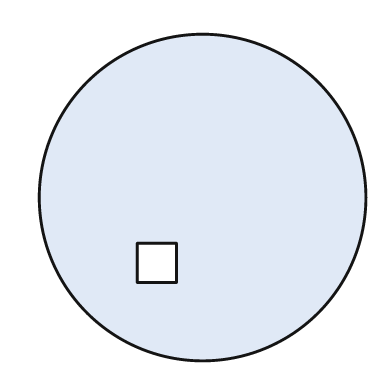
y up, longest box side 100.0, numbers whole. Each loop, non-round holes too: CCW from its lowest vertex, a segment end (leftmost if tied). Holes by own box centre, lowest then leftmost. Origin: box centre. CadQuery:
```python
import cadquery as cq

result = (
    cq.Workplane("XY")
    .moveTo(0.0, 0.0)
    .circle(50.0)
    .moveTo(-20.0, -26.0)
    .lineTo(-8.0, -26.0)
    .lineTo(-8.0, -14.0)
    .lineTo(-20.0, -14.0)
    .close()
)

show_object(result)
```